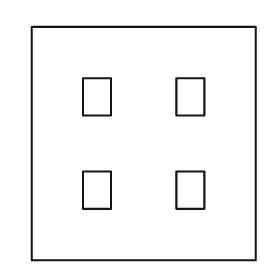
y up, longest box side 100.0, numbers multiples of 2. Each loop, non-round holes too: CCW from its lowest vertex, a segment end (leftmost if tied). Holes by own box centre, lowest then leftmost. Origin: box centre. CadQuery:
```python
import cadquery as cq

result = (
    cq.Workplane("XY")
    .moveTo(-48.0, -50.0)
    .lineTo(48.0, -50.0)
    .lineTo(48.0, 50.0)
    .lineTo(-48.0, 50.0)
    .close()
    .moveTo(-26.0, -28.0)
    .lineTo(-14.0, -28.0)
    .lineTo(-14.0, -12.0)
    .lineTo(-26.0, -12.0)
    .close()
    .moveTo(14.0, -28.0)
    .lineTo(26.0, -28.0)
    .lineTo(26.0, -12.0)
    .lineTo(14.0, -12.0)
    .close()
    .moveTo(-26.0, 12.0)
    .lineTo(-14.0, 12.0)
    .lineTo(-14.0, 28.0)
    .lineTo(-26.0, 28.0)
    .close()
    .moveTo(14.0, 12.0)
    .lineTo(26.0, 12.0)
    .lineTo(26.0, 28.0)
    .lineTo(14.0, 28.0)
    .close()
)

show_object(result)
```